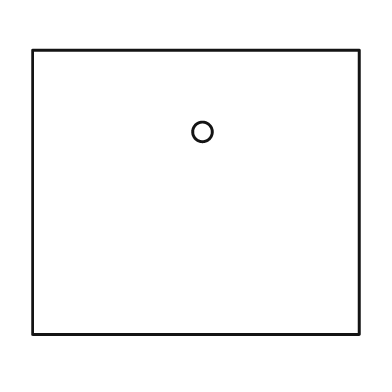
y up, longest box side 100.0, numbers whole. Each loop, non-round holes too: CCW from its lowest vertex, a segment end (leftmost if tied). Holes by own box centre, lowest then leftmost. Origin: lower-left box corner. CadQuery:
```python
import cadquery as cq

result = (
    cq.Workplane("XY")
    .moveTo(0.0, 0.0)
    .lineTo(100.0, 0.0)
    .lineTo(100.0, 87.0)
    .lineTo(0.0, 87.0)
    .close()
    .moveTo(52.0, 62.0)
    .circle(3.0)
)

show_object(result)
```